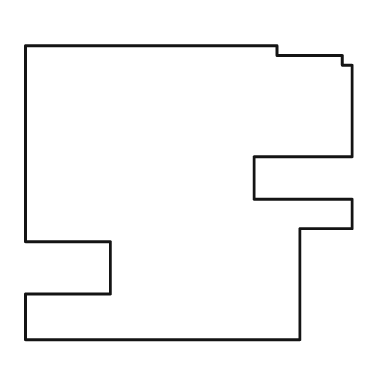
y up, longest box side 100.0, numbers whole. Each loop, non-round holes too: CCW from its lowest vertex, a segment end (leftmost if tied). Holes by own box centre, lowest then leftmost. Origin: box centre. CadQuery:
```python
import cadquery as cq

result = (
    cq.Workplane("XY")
    .moveTo(-50.0, -45.0)
    .lineTo(34.0, -45.0)
    .lineTo(34.0, -11.0)
    .lineTo(50.0, -11.0)
    .lineTo(50.0, -2.0)
    .lineTo(20.0, -2.0)
    .lineTo(20.0, 11.0)
    .lineTo(50.0, 11.0)
    .lineTo(50.0, 39.0)
    .lineTo(47.0, 39.0)
    .lineTo(47.0, 42.0)
    .lineTo(27.0, 42.0)
    .lineTo(27.0, 45.0)
    .lineTo(-50.0, 45.0)
    .lineTo(-50.0, -15.0)
    .lineTo(-24.0, -15.0)
    .lineTo(-24.0, -31.0)
    .lineTo(-50.0, -31.0)
    .close()
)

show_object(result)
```